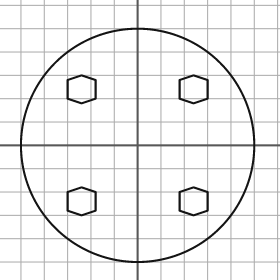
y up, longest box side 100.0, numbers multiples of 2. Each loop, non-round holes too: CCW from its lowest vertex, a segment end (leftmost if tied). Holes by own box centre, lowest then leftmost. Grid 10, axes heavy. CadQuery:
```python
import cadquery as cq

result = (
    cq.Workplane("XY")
    .moveTo(0.0, 0.0)
    .circle(50.0)
    .moveTo(-24.0, -30.0)
    .lineTo(-18.0, -28.0)
    .lineTo(-18.0, -20.0)
    .lineTo(-24.0, -18.0)
    .lineTo(-30.0, -20.0)
    .lineTo(-30.0, -28.0)
    .close()
    .moveTo(24.0, -30.0)
    .lineTo(30.0, -28.0)
    .lineTo(30.0, -20.0)
    .lineTo(24.0, -18.0)
    .lineTo(18.0, -20.0)
    .lineTo(18.0, -28.0)
    .close()
    .moveTo(-24.0, 18.0)
    .lineTo(-18.0, 20.0)
    .lineTo(-18.0, 28.0)
    .lineTo(-24.0, 30.0)
    .lineTo(-30.0, 28.0)
    .lineTo(-30.0, 20.0)
    .close()
    .moveTo(24.0, 18.0)
    .lineTo(30.0, 20.0)
    .lineTo(30.0, 28.0)
    .lineTo(24.0, 30.0)
    .lineTo(18.0, 28.0)
    .lineTo(18.0, 20.0)
    .close()
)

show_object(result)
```